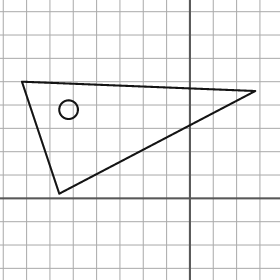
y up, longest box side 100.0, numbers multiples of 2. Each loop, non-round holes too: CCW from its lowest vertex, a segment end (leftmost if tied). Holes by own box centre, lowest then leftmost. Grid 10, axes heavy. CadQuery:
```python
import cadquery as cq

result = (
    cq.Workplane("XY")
    .moveTo(-56.0, 2.0)
    .lineTo(28.0, 46.0)
    .lineTo(-72.0, 50.0)
    .close()
    .moveTo(-52.0, 38.0)
    .circle(4.0)
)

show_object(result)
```